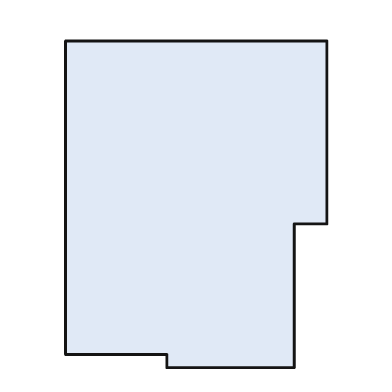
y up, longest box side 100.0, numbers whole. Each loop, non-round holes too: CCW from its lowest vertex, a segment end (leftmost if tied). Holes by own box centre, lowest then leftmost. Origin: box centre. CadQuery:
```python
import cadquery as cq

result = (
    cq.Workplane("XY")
    .moveTo(-9.0, -50.0)
    .lineTo(30.0, -50.0)
    .lineTo(30.0, -6.0)
    .lineTo(40.0, -6.0)
    .lineTo(40.0, 50.0)
    .lineTo(-40.0, 50.0)
    .lineTo(-40.0, -46.0)
    .lineTo(-9.0, -46.0)
    .close()
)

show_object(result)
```